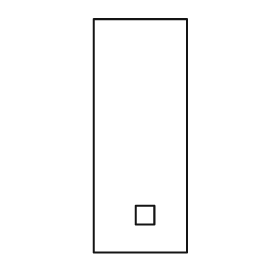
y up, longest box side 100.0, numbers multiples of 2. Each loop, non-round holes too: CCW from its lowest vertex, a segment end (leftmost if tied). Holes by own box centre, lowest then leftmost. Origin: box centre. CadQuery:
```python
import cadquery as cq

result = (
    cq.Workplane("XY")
    .moveTo(-20.0, -50.0)
    .lineTo(20.0, -50.0)
    .lineTo(20.0, 50.0)
    .lineTo(-20.0, 50.0)
    .close()
    .moveTo(-2.0, -38.0)
    .lineTo(6.0, -38.0)
    .lineTo(6.0, -30.0)
    .lineTo(-2.0, -30.0)
    .close()
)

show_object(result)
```